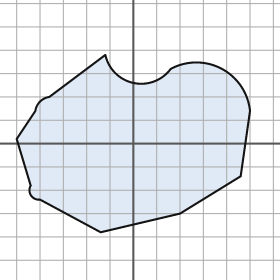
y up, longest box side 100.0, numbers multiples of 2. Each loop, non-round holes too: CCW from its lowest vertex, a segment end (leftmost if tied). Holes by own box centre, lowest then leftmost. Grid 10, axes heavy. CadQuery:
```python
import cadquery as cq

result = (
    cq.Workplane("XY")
    .moveTo(-14.0, -38.0)
    .lineTo(20.0, -30.0)
    .lineTo(46.0, -14.0)
    .lineTo(50.0, 14.0)
    .threePointArc((38.0, 32.0), (16.0, 32.0))
    .threePointArc((0.0, 26.0), (-12.0, 38.0))
    .lineTo(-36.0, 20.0)
    .threePointArc((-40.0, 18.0), (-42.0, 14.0))
    .lineTo(-50.0, 2.0)
    .lineTo(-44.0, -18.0)
    .threePointArc((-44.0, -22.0), (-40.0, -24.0))
    .close()
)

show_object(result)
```